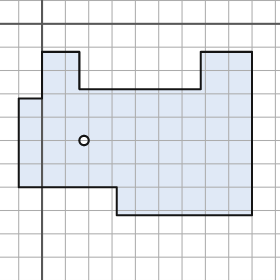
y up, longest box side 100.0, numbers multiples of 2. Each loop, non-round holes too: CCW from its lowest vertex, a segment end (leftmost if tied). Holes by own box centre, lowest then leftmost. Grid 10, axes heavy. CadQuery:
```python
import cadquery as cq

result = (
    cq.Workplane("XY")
    .moveTo(32.0, -82.0)
    .lineTo(90.0, -82.0)
    .lineTo(90.0, -12.0)
    .lineTo(68.0, -12.0)
    .lineTo(68.0, -28.0)
    .lineTo(16.0, -28.0)
    .lineTo(16.0, -12.0)
    .lineTo(0.0, -12.0)
    .lineTo(0.0, -32.0)
    .lineTo(-10.0, -32.0)
    .lineTo(-10.0, -70.0)
    .lineTo(32.0, -70.0)
    .close()
    .moveTo(18.0, -50.0)
    .circle(2.0)
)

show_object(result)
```